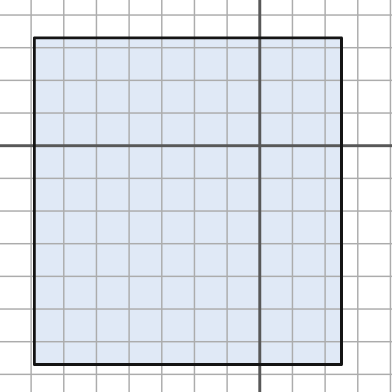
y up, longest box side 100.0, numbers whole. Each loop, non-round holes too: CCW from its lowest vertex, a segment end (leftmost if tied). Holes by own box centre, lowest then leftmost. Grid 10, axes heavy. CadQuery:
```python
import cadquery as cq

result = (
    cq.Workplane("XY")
    .moveTo(-69.0, -67.0)
    .lineTo(25.0, -67.0)
    .lineTo(25.0, 33.0)
    .lineTo(-69.0, 33.0)
    .close()
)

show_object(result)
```